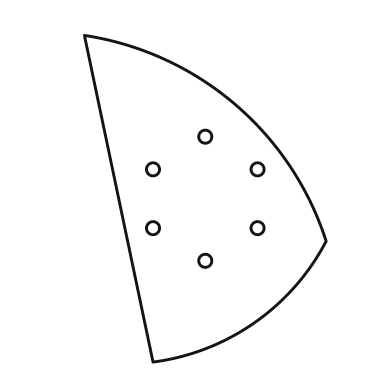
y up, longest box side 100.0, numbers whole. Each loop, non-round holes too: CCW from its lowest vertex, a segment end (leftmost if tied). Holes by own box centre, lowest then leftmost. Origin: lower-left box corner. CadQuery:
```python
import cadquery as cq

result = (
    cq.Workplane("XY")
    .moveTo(21.0, 0.0)
    .threePointArc((52.0, 12.0), (74.0, 37.0))
    .threePointArc((46.0, 79.0), (0.0, 100.0))
    .close()
    .moveTo(37.0, 31.0)
    .circle(2.0)
    .moveTo(21.0, 41.0)
    .circle(2.0)
    .moveTo(53.0, 41.0)
    .circle(2.0)
    .moveTo(21.0, 59.0)
    .circle(2.0)
    .moveTo(53.0, 59.0)
    .circle(2.0)
    .moveTo(37.0, 69.0)
    .circle(2.0)
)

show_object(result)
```